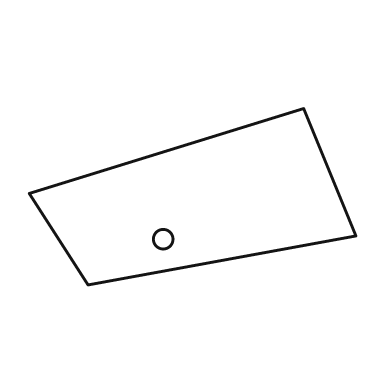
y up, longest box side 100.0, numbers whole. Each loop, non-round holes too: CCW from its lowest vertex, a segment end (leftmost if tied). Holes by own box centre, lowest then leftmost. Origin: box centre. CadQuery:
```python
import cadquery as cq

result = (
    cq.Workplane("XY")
    .moveTo(-32.0, -27.0)
    .lineTo(50.0, -12.0)
    .lineTo(34.0, 27.0)
    .lineTo(-50.0, 1.0)
    .close()
    .moveTo(-9.0, -13.0)
    .circle(3.0)
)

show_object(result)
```